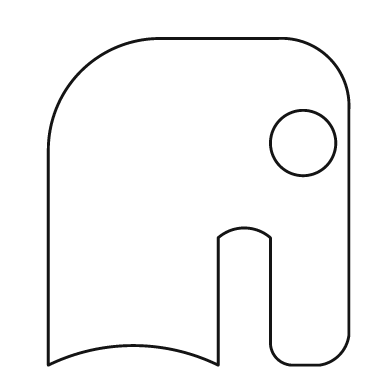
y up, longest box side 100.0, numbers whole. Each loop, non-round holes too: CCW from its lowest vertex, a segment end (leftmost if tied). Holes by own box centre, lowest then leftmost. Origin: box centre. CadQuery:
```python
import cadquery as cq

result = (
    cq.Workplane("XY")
    .moveTo(-46.0, -50.0)
    .threePointArc((-20.0, -44.0), (6.0, -50.0))
    .lineTo(6.0, -11.0)
    .threePointArc((14.0, -8.0), (22.0, -11.0))
    .lineTo(22.0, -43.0)
    .threePointArc((24.0, -48.0), (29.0, -50.0))
    .lineTo(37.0, -50.0)
    .threePointArc((43.0, -47.0), (46.0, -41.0))
    .lineTo(46.0, 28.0)
    .threePointArc((40.0, 44.0), (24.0, 50.0))
    .lineTo(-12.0, 50.0)
    .threePointArc((-36.0, 40.0), (-46.0, 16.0))
    .close()
    .moveTo(32.0, 18.0)
    .circle(10.0)
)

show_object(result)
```